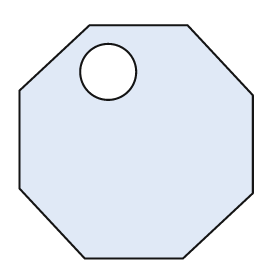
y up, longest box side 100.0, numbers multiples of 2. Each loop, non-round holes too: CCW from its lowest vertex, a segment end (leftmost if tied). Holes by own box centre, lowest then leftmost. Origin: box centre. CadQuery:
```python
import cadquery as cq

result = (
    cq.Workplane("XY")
    .moveTo(-22.0, -50.0)
    .lineTo(20.0, -50.0)
    .lineTo(50.0, -22.0)
    .lineTo(50.0, 20.0)
    .lineTo(22.0, 50.0)
    .lineTo(-20.0, 50.0)
    .lineTo(-50.0, 22.0)
    .lineTo(-50.0, -20.0)
    .close()
    .moveTo(-12.0, 30.0)
    .circle(12.0)
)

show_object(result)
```